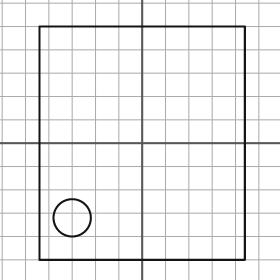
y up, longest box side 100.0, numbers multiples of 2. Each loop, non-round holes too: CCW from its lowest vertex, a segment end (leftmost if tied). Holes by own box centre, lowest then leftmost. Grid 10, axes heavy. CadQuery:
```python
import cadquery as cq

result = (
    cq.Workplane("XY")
    .moveTo(-44.0, -50.0)
    .lineTo(44.0, -50.0)
    .lineTo(44.0, 50.0)
    .lineTo(-44.0, 50.0)
    .close()
    .moveTo(-30.0, -32.0)
    .circle(8.0)
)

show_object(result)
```